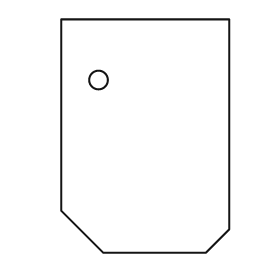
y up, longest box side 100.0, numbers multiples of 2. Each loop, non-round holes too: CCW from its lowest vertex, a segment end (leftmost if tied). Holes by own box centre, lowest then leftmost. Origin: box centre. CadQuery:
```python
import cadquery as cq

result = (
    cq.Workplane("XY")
    .moveTo(-18.0, -50.0)
    .lineTo(26.0, -50.0)
    .lineTo(36.0, -40.0)
    .lineTo(36.0, 50.0)
    .lineTo(-36.0, 50.0)
    .lineTo(-36.0, -32.0)
    .close()
    .moveTo(-20.0, 24.0)
    .circle(4.0)
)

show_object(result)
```